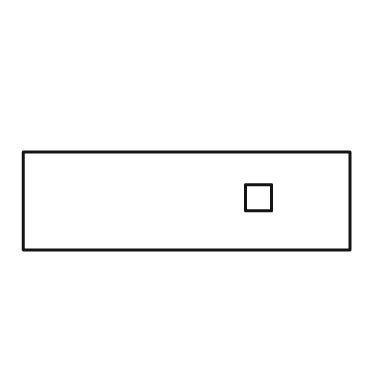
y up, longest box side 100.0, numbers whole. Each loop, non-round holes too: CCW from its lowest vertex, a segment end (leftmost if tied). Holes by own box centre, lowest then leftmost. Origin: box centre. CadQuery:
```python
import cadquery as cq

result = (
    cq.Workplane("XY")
    .moveTo(-50.0, -15.0)
    .lineTo(50.0, -15.0)
    .lineTo(50.0, 15.0)
    .lineTo(-50.0, 15.0)
    .close()
    .moveTo(18.0, -3.0)
    .lineTo(26.0, -3.0)
    .lineTo(26.0, 5.0)
    .lineTo(18.0, 5.0)
    .close()
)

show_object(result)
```